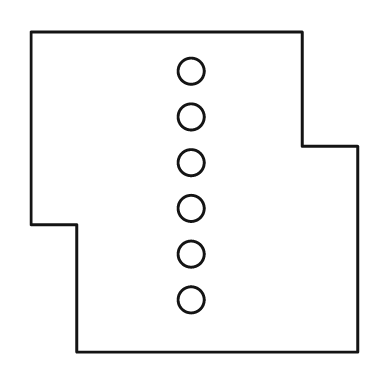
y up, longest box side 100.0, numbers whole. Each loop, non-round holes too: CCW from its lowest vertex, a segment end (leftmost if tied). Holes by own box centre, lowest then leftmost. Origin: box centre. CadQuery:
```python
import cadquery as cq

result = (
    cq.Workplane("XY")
    .moveTo(-36.0, -49.0)
    .lineTo(50.0, -49.0)
    .lineTo(50.0, 14.0)
    .lineTo(33.0, 14.0)
    .lineTo(33.0, 49.0)
    .lineTo(-50.0, 49.0)
    .lineTo(-50.0, -10.0)
    .lineTo(-36.0, -10.0)
    .close()
    .moveTo(-1.0, -33.0)
    .circle(4.0)
    .moveTo(-1.0, -19.0)
    .circle(4.0)
    .moveTo(-1.0, -5.0)
    .circle(4.0)
    .moveTo(-1.0, 9.0)
    .circle(4.0)
    .moveTo(-1.0, 23.0)
    .circle(4.0)
    .moveTo(-1.0, 37.0)
    .circle(4.0)
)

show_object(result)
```